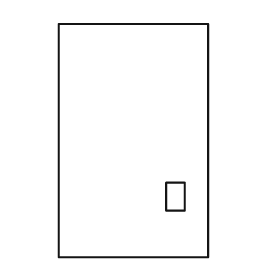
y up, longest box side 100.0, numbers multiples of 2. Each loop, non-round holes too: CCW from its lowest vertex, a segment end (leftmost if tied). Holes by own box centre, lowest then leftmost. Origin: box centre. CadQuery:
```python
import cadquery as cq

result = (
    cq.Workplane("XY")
    .moveTo(-32.0, -50.0)
    .lineTo(32.0, -50.0)
    .lineTo(32.0, 50.0)
    .lineTo(-32.0, 50.0)
    .close()
    .moveTo(14.0, -30.0)
    .lineTo(22.0, -30.0)
    .lineTo(22.0, -18.0)
    .lineTo(14.0, -18.0)
    .close()
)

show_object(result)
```